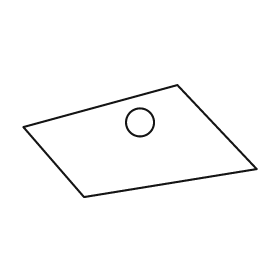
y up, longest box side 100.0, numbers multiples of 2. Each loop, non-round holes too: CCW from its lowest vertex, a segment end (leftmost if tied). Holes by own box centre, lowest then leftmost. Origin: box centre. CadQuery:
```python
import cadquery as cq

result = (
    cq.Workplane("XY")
    .moveTo(-24.0, -24.0)
    .lineTo(50.0, -12.0)
    .lineTo(16.0, 24.0)
    .lineTo(-50.0, 6.0)
    .close()
    .moveTo(0.0, 8.0)
    .circle(6.0)
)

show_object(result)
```